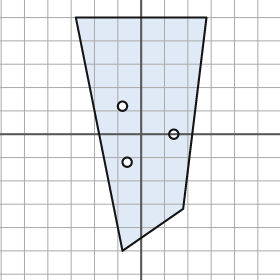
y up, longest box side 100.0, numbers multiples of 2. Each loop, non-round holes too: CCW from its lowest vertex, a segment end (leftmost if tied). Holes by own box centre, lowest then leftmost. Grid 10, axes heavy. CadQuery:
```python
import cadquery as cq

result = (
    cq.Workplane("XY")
    .moveTo(-8.0, -50.0)
    .lineTo(18.0, -32.0)
    .lineTo(28.0, 50.0)
    .lineTo(-28.0, 50.0)
    .close()
    .moveTo(-6.0, -12.0)
    .circle(2.0)
    .moveTo(14.0, 0.0)
    .circle(2.0)
    .moveTo(-8.0, 12.0)
    .circle(2.0)
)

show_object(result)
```